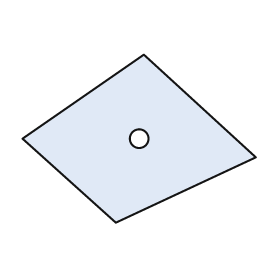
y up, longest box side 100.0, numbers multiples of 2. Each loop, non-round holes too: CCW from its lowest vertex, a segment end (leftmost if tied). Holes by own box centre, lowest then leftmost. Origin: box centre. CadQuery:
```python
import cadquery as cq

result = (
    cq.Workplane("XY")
    .moveTo(-10.0, -36.0)
    .lineTo(50.0, -8.0)
    .lineTo(2.0, 36.0)
    .lineTo(-50.0, 0.0)
    .close()
    .moveTo(0.0, 0.0)
    .circle(4.0)
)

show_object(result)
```